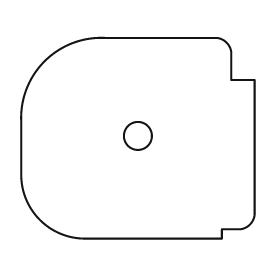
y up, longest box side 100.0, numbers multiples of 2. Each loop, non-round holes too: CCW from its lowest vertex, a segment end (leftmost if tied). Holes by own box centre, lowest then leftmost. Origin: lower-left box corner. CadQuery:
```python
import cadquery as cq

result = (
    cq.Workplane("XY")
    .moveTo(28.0, 0.0)
    .lineTo(86.0, 0.0)
    .lineTo(86.0, 4.0)
    .lineTo(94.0, 4.0)
    .threePointArc((98.0, 6.0), (100.0, 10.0))
    .lineTo(100.0, 68.0)
    .lineTo(90.0, 68.0)
    .lineTo(90.0, 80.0)
    .threePointArc((88.0, 84.0), (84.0, 86.0))
    .lineTo(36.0, 86.0)
    .threePointArc((10.0, 76.0), (0.0, 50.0))
    .lineTo(0.0, 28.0)
    .threePointArc((8.0, 8.0), (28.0, 0.0))
    .close()
    .moveTo(50.0, 44.0)
    .circle(6.0)
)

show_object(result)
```